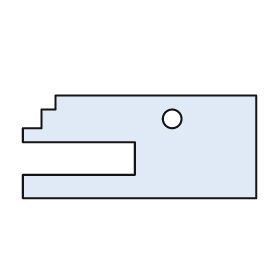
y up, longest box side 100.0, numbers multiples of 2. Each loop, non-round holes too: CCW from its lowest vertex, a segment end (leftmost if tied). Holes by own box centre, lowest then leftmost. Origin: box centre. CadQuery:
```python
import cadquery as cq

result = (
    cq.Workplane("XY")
    .moveTo(-50.0, -22.0)
    .lineTo(50.0, -22.0)
    .lineTo(50.0, 22.0)
    .lineTo(-36.0, 22.0)
    .lineTo(-36.0, 16.0)
    .lineTo(-42.0, 16.0)
    .lineTo(-42.0, 8.0)
    .lineTo(-50.0, 8.0)
    .lineTo(-50.0, 2.0)
    .lineTo(-2.0, 2.0)
    .lineTo(-2.0, -12.0)
    .lineTo(-50.0, -12.0)
    .close()
    .moveTo(14.0, 12.0)
    .circle(4.0)
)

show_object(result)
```